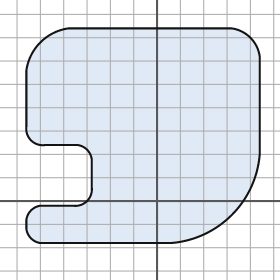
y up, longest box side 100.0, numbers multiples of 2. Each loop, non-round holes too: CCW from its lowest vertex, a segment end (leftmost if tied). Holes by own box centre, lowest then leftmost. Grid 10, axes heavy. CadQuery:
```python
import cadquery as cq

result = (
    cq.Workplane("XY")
    .moveTo(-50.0, -18.0)
    .lineTo(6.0, -18.0)
    .threePointArc((32.0, -6.0), (44.0, 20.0))
    .lineTo(44.0, 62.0)
    .threePointArc((40.0, 70.0), (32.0, 74.0))
    .lineTo(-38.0, 74.0)
    .threePointArc((-50.0, 68.0), (-56.0, 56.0))
    .lineTo(-56.0, 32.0)
    .threePointArc((-54.0, 26.0), (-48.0, 24.0))
    .lineTo(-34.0, 24.0)
    .threePointArc((-30.0, 22.0), (-28.0, 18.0))
    .lineTo(-28.0, 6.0)
    .threePointArc((-30.0, 0.0), (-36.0, -2.0))
    .lineTo(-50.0, -2.0)
    .threePointArc((-54.0, -4.0), (-56.0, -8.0))
    .lineTo(-56.0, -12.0)
    .threePointArc((-54.0, -16.0), (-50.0, -18.0))
    .close()
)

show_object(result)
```